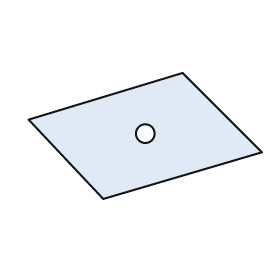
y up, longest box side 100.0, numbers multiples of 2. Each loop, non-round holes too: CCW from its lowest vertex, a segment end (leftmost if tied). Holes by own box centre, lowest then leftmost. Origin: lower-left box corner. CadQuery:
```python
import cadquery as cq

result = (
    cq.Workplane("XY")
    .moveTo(32.0, 0.0)
    .lineTo(100.0, 20.0)
    .lineTo(66.0, 54.0)
    .lineTo(0.0, 34.0)
    .close()
    .moveTo(50.0, 28.0)
    .circle(4.0)
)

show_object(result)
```